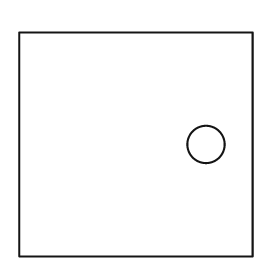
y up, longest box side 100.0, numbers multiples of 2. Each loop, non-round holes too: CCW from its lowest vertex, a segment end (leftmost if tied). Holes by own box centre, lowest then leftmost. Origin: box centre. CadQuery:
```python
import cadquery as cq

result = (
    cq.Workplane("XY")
    .moveTo(-50.0, -48.0)
    .lineTo(50.0, -48.0)
    .lineTo(50.0, 48.0)
    .lineTo(-50.0, 48.0)
    .close()
    .moveTo(30.0, 0.0)
    .circle(8.0)
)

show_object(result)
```